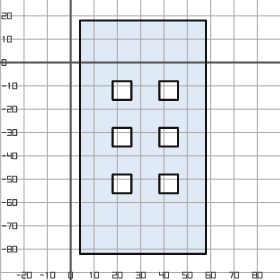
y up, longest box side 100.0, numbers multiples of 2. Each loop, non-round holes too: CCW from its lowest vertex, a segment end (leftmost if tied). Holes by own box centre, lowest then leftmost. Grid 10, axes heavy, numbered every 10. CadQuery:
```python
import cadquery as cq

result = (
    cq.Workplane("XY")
    .moveTo(4.0, -82.0)
    .lineTo(58.0, -82.0)
    .lineTo(58.0, 18.0)
    .lineTo(4.0, 18.0)
    .close()
    .moveTo(18.0, -56.0)
    .lineTo(26.0, -56.0)
    .lineTo(26.0, -48.0)
    .lineTo(18.0, -48.0)
    .close()
    .moveTo(38.0, -56.0)
    .lineTo(46.0, -56.0)
    .lineTo(46.0, -48.0)
    .lineTo(38.0, -48.0)
    .close()
    .moveTo(18.0, -36.0)
    .lineTo(26.0, -36.0)
    .lineTo(26.0, -28.0)
    .lineTo(18.0, -28.0)
    .close()
    .moveTo(38.0, -36.0)
    .lineTo(46.0, -36.0)
    .lineTo(46.0, -28.0)
    .lineTo(38.0, -28.0)
    .close()
    .moveTo(18.0, -16.0)
    .lineTo(26.0, -16.0)
    .lineTo(26.0, -8.0)
    .lineTo(18.0, -8.0)
    .close()
    .moveTo(38.0, -16.0)
    .lineTo(46.0, -16.0)
    .lineTo(46.0, -8.0)
    .lineTo(38.0, -8.0)
    .close()
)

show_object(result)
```